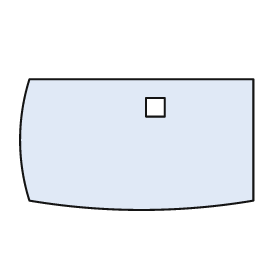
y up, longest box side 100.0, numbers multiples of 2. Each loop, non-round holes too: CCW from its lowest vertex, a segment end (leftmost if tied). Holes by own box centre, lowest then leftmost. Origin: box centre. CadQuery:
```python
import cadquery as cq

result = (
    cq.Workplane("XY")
    .moveTo(-46.0, -24.0)
    .threePointArc((2.0, -28.0), (50.0, -24.0))
    .lineTo(50.0, 28.0)
    .lineTo(-46.0, 28.0)
    .threePointArc((-50.0, 2.0), (-46.0, -24.0))
    .close()
    .moveTo(4.0, 12.0)
    .lineTo(12.0, 12.0)
    .lineTo(12.0, 20.0)
    .lineTo(4.0, 20.0)
    .close()
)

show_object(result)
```